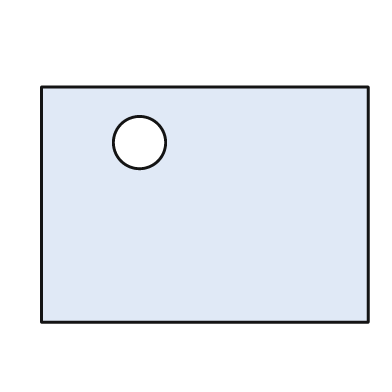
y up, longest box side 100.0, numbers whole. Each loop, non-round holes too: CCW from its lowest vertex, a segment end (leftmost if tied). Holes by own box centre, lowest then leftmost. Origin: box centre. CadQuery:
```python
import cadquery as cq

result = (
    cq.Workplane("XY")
    .moveTo(-50.0, -36.0)
    .lineTo(50.0, -36.0)
    .lineTo(50.0, 36.0)
    .lineTo(-50.0, 36.0)
    .close()
    .moveTo(-20.0, 19.0)
    .circle(8.0)
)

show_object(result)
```